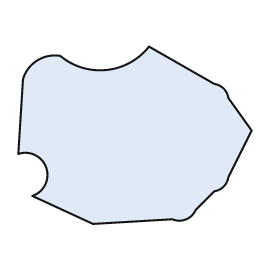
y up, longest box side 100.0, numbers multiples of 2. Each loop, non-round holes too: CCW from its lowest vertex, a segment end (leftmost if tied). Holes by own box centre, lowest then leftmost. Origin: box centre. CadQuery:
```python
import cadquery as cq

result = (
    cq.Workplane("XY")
    .moveTo(-18.0, -38.0)
    .lineTo(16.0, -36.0)
    .threePointArc((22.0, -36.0), (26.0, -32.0))
    .lineTo(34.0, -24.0)
    .threePointArc((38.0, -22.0), (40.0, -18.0))
    .lineTo(50.0, 2.0)
    .lineTo(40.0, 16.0)
    .threePointArc((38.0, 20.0), (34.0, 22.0))
    .lineTo(6.0, 38.0)
    .threePointArc((-12.0, 28.0), (-32.0, 34.0))
    .threePointArc((-42.0, 32.0), (-48.0, 24.0))
    .lineTo(-50.0, -8.0)
    .threePointArc((-38.0, -14.0), (-44.0, -26.0))
    .close()
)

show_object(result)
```